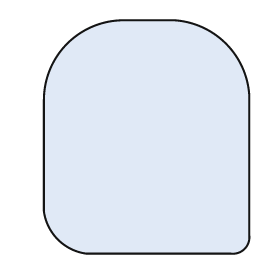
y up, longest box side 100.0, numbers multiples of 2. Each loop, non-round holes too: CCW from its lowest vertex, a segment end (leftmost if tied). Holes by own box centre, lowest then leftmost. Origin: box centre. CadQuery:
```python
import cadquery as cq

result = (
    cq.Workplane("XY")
    .moveTo(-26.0, -50.0)
    .lineTo(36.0, -50.0)
    .threePointArc((42.0, -48.0), (44.0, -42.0))
    .lineTo(44.0, 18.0)
    .threePointArc((34.0, 40.0), (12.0, 50.0))
    .lineTo(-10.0, 50.0)
    .threePointArc((-34.0, 40.0), (-44.0, 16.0))
    .lineTo(-44.0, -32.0)
    .threePointArc((-38.0, -44.0), (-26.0, -50.0))
    .close()
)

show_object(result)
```